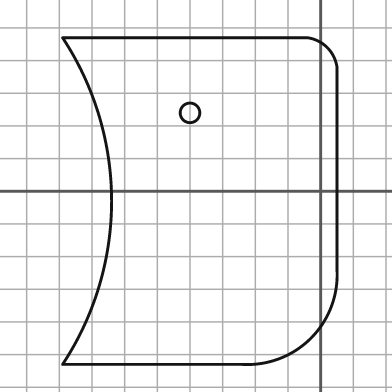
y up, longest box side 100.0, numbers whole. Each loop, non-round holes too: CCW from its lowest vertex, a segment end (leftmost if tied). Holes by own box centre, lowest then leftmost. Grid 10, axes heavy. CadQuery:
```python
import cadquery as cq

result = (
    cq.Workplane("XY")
    .moveTo(-79.0, -53.0)
    .lineTo(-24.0, -53.0)
    .threePointArc((-3.0, -45.0), (5.0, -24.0))
    .lineTo(5.0, 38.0)
    .threePointArc((2.0, 44.0), (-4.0, 47.0))
    .lineTo(-79.0, 47.0)
    .threePointArc((-64.0, -3.0), (-79.0, -53.0))
    .close()
    .moveTo(-40.0, 24.0)
    .circle(3.0)
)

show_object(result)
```